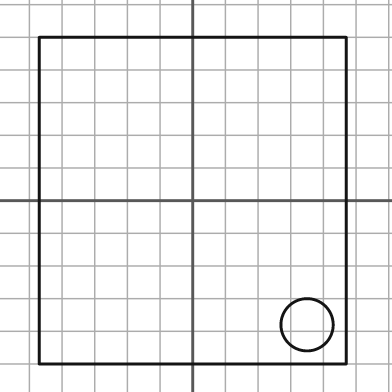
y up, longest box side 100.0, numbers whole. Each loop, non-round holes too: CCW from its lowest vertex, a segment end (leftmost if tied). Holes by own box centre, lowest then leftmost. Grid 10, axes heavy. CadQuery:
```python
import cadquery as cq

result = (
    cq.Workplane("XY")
    .moveTo(-47.0, -50.0)
    .lineTo(47.0, -50.0)
    .lineTo(47.0, 50.0)
    .lineTo(-47.0, 50.0)
    .close()
    .moveTo(35.0, -38.0)
    .circle(8.0)
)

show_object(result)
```